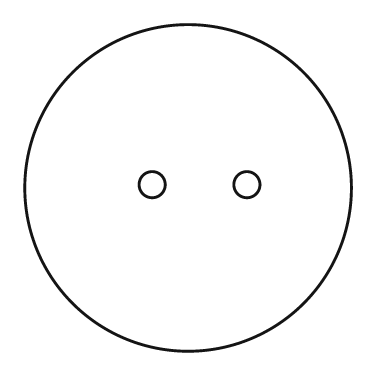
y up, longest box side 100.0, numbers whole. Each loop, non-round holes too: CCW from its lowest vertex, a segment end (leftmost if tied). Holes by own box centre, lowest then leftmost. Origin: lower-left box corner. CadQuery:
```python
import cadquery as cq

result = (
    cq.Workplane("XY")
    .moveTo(50.0, 50.0)
    .circle(50.0)
    .moveTo(39.0, 51.0)
    .circle(4.0)
    .moveTo(68.0, 51.0)
    .circle(4.0)
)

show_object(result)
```